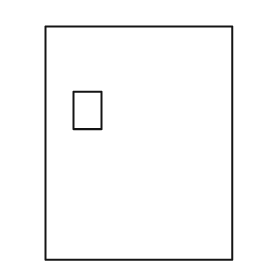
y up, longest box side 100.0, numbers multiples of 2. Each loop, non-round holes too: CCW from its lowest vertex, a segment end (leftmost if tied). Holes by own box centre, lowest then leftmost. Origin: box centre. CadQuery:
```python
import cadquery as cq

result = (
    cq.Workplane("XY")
    .moveTo(-40.0, -50.0)
    .lineTo(40.0, -50.0)
    .lineTo(40.0, 50.0)
    .lineTo(-40.0, 50.0)
    .close()
    .moveTo(-28.0, 6.0)
    .lineTo(-16.0, 6.0)
    .lineTo(-16.0, 22.0)
    .lineTo(-28.0, 22.0)
    .close()
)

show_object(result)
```